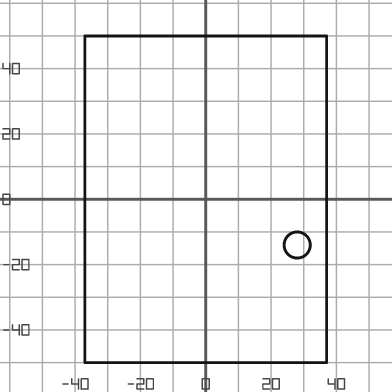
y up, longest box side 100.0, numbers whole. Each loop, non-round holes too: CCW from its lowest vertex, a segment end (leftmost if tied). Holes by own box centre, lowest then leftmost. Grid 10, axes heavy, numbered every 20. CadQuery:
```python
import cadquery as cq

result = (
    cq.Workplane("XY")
    .moveTo(-37.0, -50.0)
    .lineTo(37.0, -50.0)
    .lineTo(37.0, 50.0)
    .lineTo(-37.0, 50.0)
    .close()
    .moveTo(28.0, -14.0)
    .circle(4.0)
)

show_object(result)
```